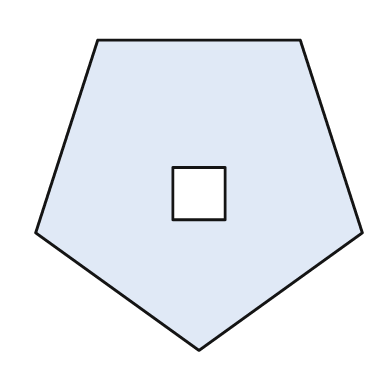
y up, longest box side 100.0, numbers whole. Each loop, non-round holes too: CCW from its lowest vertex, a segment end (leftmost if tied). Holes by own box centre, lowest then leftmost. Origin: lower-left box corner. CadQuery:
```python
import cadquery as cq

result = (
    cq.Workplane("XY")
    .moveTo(50.0, 0.0)
    .lineTo(100.0, 36.0)
    .lineTo(81.0, 95.0)
    .lineTo(19.0, 95.0)
    .lineTo(0.0, 36.0)
    .close()
    .moveTo(42.0, 40.0)
    .lineTo(58.0, 40.0)
    .lineTo(58.0, 56.0)
    .lineTo(42.0, 56.0)
    .close()
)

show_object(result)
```